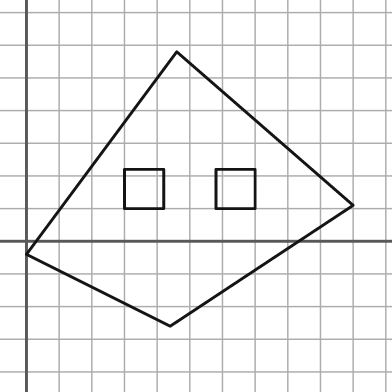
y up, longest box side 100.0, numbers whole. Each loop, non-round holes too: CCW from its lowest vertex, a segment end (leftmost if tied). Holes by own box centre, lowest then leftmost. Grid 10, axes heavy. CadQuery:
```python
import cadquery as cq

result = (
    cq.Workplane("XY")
    .moveTo(44.0, -26.0)
    .lineTo(100.0, 11.0)
    .lineTo(46.0, 58.0)
    .lineTo(0.0, -4.0)
    .close()
    .moveTo(30.0, 10.0)
    .lineTo(42.0, 10.0)
    .lineTo(42.0, 22.0)
    .lineTo(30.0, 22.0)
    .close()
    .moveTo(58.0, 10.0)
    .lineTo(70.0, 10.0)
    .lineTo(70.0, 22.0)
    .lineTo(58.0, 22.0)
    .close()
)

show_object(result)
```